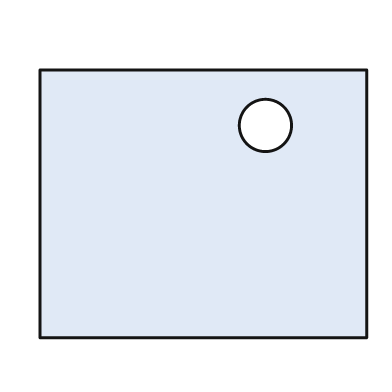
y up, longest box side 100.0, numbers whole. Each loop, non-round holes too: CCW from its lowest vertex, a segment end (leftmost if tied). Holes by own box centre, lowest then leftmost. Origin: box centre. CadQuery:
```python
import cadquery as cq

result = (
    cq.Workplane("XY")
    .moveTo(-50.0, -41.0)
    .lineTo(50.0, -41.0)
    .lineTo(50.0, 41.0)
    .lineTo(-50.0, 41.0)
    .close()
    .moveTo(19.0, 24.0)
    .circle(8.0)
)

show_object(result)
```